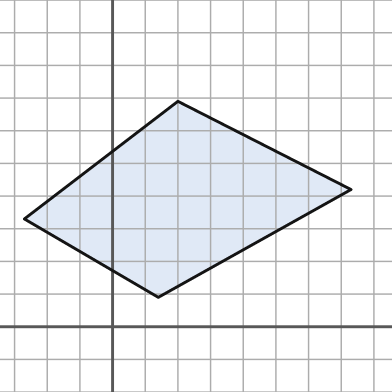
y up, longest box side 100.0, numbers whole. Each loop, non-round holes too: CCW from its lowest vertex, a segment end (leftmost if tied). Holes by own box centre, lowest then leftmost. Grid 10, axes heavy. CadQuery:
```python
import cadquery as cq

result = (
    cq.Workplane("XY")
    .moveTo(14.0, 9.0)
    .lineTo(73.0, 42.0)
    .lineTo(20.0, 69.0)
    .lineTo(-27.0, 33.0)
    .close()
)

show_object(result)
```